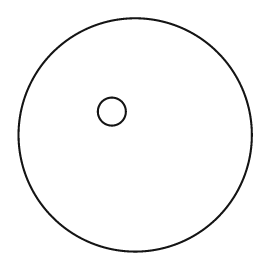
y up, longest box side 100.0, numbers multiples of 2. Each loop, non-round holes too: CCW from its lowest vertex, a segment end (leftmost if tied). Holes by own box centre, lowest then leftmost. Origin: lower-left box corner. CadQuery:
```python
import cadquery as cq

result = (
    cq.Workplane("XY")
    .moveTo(50.0, 50.0)
    .circle(50.0)
    .moveTo(40.0, 60.0)
    .circle(6.0)
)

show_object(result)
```